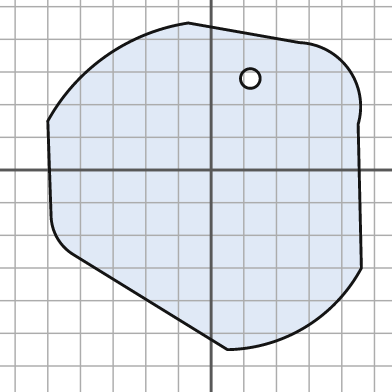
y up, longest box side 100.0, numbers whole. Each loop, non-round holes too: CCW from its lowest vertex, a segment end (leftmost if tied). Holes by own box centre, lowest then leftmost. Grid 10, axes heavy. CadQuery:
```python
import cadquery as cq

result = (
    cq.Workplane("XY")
    .moveTo(5.0, -55.0)
    .threePointArc((29.0, -48.0), (46.0, -30.0))
    .lineTo(45.0, 14.0)
    .threePointArc((42.0, 31.0), (27.0, 39.0))
    .lineTo(-7.0, 45.0)
    .threePointArc((-32.0, 35.0), (-50.0, 15.0))
    .lineTo(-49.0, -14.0)
    .threePointArc((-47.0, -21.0), (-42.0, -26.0))
    .close()
    .moveTo(12.0, 28.0)
    .circle(3.0)
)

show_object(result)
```